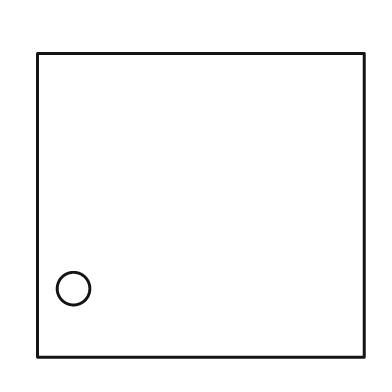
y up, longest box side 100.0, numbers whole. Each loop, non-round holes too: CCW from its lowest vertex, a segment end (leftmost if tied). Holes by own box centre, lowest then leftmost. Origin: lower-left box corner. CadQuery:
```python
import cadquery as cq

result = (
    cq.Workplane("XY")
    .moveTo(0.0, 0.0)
    .lineTo(100.0, 0.0)
    .lineTo(100.0, 93.0)
    .lineTo(0.0, 93.0)
    .close()
    .moveTo(11.0, 21.0)
    .circle(5.0)
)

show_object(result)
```